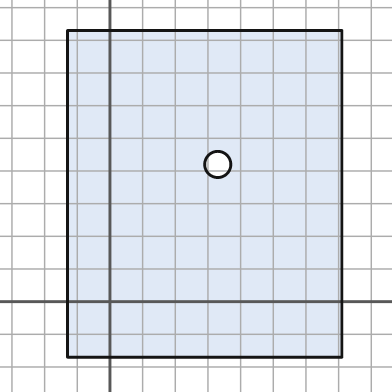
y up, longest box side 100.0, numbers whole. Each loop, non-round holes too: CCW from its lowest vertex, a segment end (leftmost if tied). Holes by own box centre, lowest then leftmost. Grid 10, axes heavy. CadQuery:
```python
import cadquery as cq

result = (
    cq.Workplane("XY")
    .moveTo(-13.0, -17.0)
    .lineTo(71.0, -17.0)
    .lineTo(71.0, 83.0)
    .lineTo(-13.0, 83.0)
    .close()
    .moveTo(33.0, 42.0)
    .circle(4.0)
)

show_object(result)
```